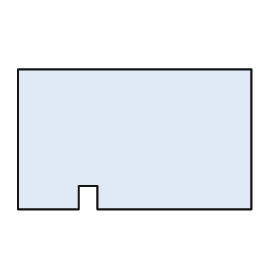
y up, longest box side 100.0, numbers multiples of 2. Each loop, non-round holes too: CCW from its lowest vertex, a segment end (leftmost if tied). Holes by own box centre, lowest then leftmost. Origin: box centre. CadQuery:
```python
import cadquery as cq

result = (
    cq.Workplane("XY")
    .moveTo(-50.0, -30.0)
    .lineTo(-24.0, -30.0)
    .lineTo(-24.0, -20.0)
    .lineTo(-16.0, -20.0)
    .lineTo(-16.0, -30.0)
    .lineTo(50.0, -30.0)
    .lineTo(50.0, 30.0)
    .lineTo(-50.0, 30.0)
    .close()
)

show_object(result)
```